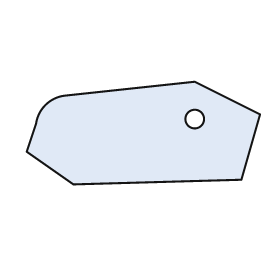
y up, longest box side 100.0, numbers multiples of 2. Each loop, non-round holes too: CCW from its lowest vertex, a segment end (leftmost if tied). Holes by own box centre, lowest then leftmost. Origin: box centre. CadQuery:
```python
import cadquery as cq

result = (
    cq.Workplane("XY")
    .moveTo(-30.0, -22.0)
    .lineTo(42.0, -20.0)
    .lineTo(50.0, 8.0)
    .lineTo(22.0, 22.0)
    .lineTo(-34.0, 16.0)
    .threePointArc((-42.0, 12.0), (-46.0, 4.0))
    .lineTo(-50.0, -8.0)
    .close()
    .moveTo(22.0, 6.0)
    .circle(4.0)
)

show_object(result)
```